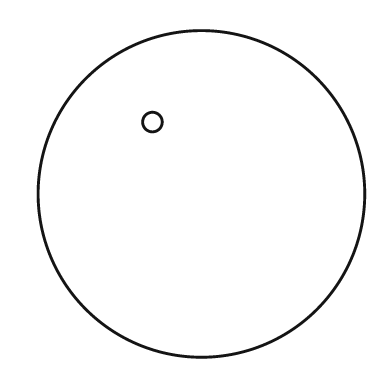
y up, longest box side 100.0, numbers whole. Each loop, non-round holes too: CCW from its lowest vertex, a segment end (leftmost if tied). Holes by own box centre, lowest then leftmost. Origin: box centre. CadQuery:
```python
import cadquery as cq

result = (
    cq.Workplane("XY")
    .moveTo(0.0, 0.0)
    .circle(50.0)
    .moveTo(-15.0, 22.0)
    .circle(3.0)
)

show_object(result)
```